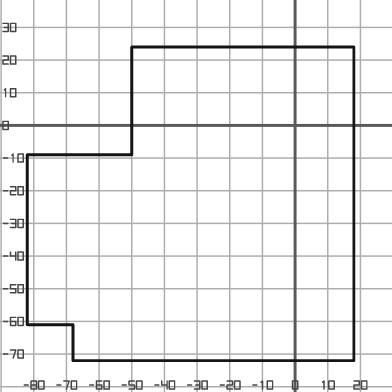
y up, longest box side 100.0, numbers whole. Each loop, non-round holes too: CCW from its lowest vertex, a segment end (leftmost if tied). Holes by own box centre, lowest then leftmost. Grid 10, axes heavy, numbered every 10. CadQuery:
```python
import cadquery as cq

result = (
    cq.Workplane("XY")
    .moveTo(-68.0, -72.0)
    .lineTo(18.0, -72.0)
    .lineTo(18.0, 24.0)
    .lineTo(-50.0, 24.0)
    .lineTo(-50.0, -9.0)
    .lineTo(-82.0, -9.0)
    .lineTo(-82.0, -61.0)
    .lineTo(-68.0, -61.0)
    .close()
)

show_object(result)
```